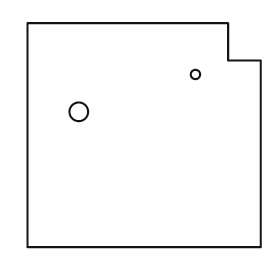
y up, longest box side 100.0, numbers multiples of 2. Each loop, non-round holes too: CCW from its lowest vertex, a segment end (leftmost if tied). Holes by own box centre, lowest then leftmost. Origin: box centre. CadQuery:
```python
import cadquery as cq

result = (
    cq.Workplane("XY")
    .moveTo(-50.0, -48.0)
    .lineTo(50.0, -48.0)
    .lineTo(50.0, 32.0)
    .lineTo(36.0, 32.0)
    .lineTo(36.0, 48.0)
    .lineTo(-50.0, 48.0)
    .close()
    .moveTo(-28.0, 10.0)
    .circle(4.0)
    .moveTo(22.0, 26.0)
    .circle(2.0)
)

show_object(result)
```